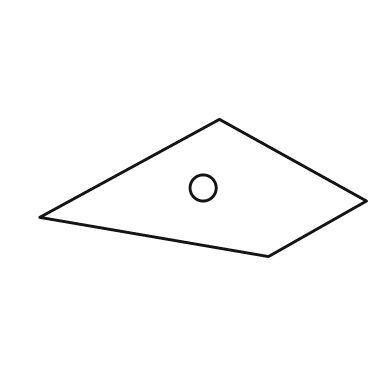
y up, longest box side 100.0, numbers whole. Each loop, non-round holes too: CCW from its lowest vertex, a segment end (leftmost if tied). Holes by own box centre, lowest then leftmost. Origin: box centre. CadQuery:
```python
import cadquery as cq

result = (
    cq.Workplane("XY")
    .moveTo(20.0, -21.0)
    .lineTo(50.0, -4.0)
    .lineTo(5.0, 21.0)
    .lineTo(-50.0, -9.0)
    .close()
    .moveTo(0.0, 0.0)
    .circle(4.0)
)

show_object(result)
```